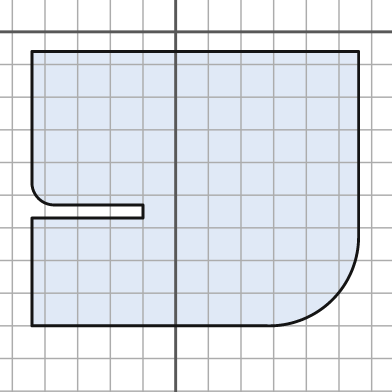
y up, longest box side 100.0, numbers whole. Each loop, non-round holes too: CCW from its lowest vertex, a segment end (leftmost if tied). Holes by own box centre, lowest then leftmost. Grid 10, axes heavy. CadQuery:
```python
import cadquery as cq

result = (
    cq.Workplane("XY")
    .moveTo(-44.0, -90.0)
    .lineTo(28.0, -90.0)
    .threePointArc((48.0, -82.0), (56.0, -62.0))
    .lineTo(56.0, -6.0)
    .lineTo(-44.0, -6.0)
    .lineTo(-44.0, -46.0)
    .threePointArc((-42.0, -51.0), (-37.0, -53.0))
    .lineTo(-10.0, -53.0)
    .lineTo(-10.0, -57.0)
    .lineTo(-44.0, -57.0)
    .close()
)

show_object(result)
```